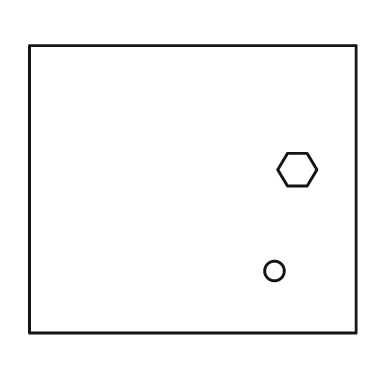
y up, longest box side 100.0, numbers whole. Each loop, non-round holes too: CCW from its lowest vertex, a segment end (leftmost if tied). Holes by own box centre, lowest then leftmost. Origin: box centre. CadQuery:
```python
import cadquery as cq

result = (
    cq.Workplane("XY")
    .moveTo(-50.0, -44.0)
    .lineTo(50.0, -44.0)
    .lineTo(50.0, 44.0)
    .lineTo(-50.0, 44.0)
    .close()
    .moveTo(25.0, -25.0)
    .circle(3.0)
    .moveTo(29.0, 1.0)
    .lineTo(35.0, 1.0)
    .lineTo(38.0, 6.0)
    .lineTo(35.0, 11.0)
    .lineTo(29.0, 11.0)
    .lineTo(26.0, 6.0)
    .close()
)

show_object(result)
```